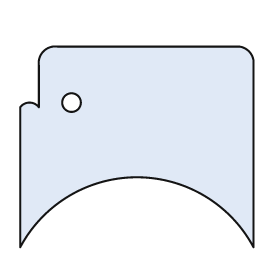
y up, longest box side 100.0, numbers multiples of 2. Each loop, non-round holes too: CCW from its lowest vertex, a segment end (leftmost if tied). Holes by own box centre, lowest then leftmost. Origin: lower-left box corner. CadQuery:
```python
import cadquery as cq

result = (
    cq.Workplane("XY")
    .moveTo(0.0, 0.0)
    .threePointArc((50.0, 30.0), (100.0, 0.0))
    .lineTo(100.0, 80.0)
    .threePointArc((98.0, 84.0), (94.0, 86.0))
    .lineTo(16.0, 86.0)
    .threePointArc((10.0, 84.0), (8.0, 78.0))
    .lineTo(8.0, 60.0)
    .threePointArc((4.0, 62.0), (0.0, 60.0))
    .close()
    .moveTo(22.0, 62.0)
    .circle(4.0)
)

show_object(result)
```